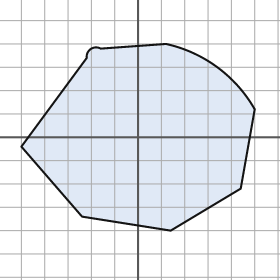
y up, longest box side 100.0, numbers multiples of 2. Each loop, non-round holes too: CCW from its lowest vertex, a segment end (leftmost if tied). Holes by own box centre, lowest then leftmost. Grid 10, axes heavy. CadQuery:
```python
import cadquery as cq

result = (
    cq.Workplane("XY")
    .moveTo(14.0, -40.0)
    .lineTo(44.0, -22.0)
    .lineTo(50.0, 12.0)
    .threePointArc((34.0, 30.0), (12.0, 40.0))
    .lineTo(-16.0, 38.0)
    .threePointArc((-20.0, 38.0), (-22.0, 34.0))
    .lineTo(-50.0, -4.0)
    .lineTo(-24.0, -34.0)
    .close()
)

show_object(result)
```